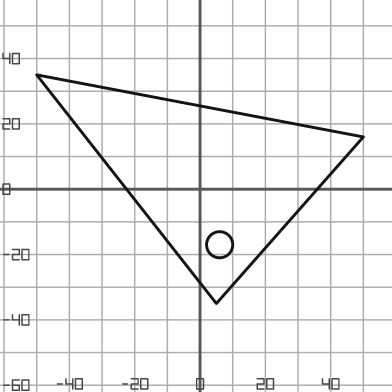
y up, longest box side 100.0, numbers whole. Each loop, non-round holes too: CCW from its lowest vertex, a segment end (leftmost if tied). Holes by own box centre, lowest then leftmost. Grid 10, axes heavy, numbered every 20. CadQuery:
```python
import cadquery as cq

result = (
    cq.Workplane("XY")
    .moveTo(5.0, -35.0)
    .lineTo(50.0, 16.0)
    .lineTo(-50.0, 35.0)
    .close()
    .moveTo(6.0, -17.0)
    .circle(4.0)
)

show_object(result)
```